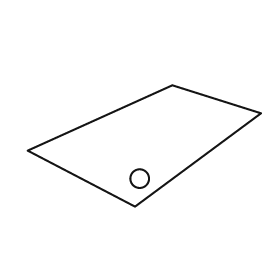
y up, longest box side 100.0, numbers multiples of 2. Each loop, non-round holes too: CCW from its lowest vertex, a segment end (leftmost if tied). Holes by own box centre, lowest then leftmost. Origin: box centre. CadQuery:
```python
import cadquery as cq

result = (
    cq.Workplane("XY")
    .moveTo(-4.0, -26.0)
    .lineTo(50.0, 14.0)
    .lineTo(12.0, 26.0)
    .lineTo(-50.0, -2.0)
    .close()
    .moveTo(-2.0, -14.0)
    .circle(4.0)
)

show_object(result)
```